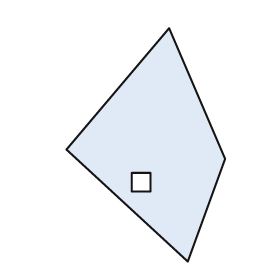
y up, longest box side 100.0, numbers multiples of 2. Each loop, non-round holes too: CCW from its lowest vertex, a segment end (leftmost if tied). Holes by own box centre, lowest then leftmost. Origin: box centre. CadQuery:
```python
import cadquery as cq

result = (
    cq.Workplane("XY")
    .moveTo(18.0, -50.0)
    .lineTo(34.0, -6.0)
    .lineTo(10.0, 50.0)
    .lineTo(-34.0, -2.0)
    .close()
    .moveTo(-6.0, -20.0)
    .lineTo(2.0, -20.0)
    .lineTo(2.0, -12.0)
    .lineTo(-6.0, -12.0)
    .close()
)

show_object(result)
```